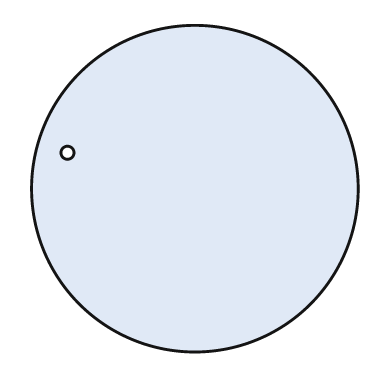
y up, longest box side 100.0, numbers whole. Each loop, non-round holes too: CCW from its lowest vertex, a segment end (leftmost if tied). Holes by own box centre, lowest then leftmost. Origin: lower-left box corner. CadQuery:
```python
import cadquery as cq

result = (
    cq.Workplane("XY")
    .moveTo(50.0, 50.0)
    .circle(50.0)
    .moveTo(11.0, 61.0)
    .circle(2.0)
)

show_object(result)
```